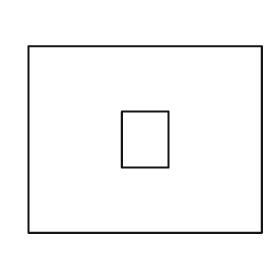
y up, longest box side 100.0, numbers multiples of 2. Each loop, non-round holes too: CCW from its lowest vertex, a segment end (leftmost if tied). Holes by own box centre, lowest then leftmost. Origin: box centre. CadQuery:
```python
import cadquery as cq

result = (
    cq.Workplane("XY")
    .moveTo(-50.0, -40.0)
    .lineTo(50.0, -40.0)
    .lineTo(50.0, 40.0)
    .lineTo(-50.0, 40.0)
    .close()
    .moveTo(-10.0, -12.0)
    .lineTo(10.0, -12.0)
    .lineTo(10.0, 12.0)
    .lineTo(-10.0, 12.0)
    .close()
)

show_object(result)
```